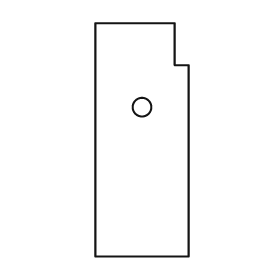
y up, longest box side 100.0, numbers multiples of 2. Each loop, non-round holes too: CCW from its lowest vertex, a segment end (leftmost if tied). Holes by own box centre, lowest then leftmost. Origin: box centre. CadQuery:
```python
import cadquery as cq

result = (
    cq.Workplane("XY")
    .moveTo(-20.0, -50.0)
    .lineTo(20.0, -50.0)
    .lineTo(20.0, 32.0)
    .lineTo(14.0, 32.0)
    .lineTo(14.0, 50.0)
    .lineTo(-20.0, 50.0)
    .close()
    .moveTo(0.0, 14.0)
    .circle(4.0)
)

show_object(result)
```